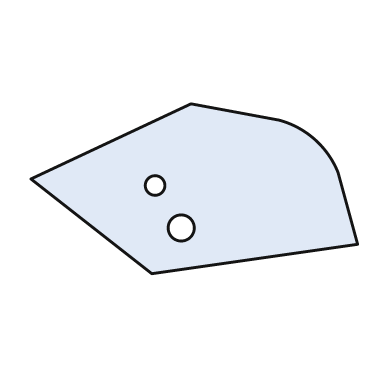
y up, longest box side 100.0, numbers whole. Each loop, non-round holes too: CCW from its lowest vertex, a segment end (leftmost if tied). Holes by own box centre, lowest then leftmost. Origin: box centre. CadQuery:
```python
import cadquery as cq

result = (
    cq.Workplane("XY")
    .moveTo(-13.0, -26.0)
    .lineTo(50.0, -17.0)
    .lineTo(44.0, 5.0)
    .threePointArc((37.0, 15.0), (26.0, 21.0))
    .lineTo(-1.0, 26.0)
    .lineTo(-50.0, 3.0)
    .close()
    .moveTo(-4.0, -12.0)
    .circle(4.0)
    .moveTo(-12.0, 1.0)
    .circle(3.0)
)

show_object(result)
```